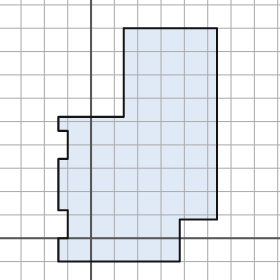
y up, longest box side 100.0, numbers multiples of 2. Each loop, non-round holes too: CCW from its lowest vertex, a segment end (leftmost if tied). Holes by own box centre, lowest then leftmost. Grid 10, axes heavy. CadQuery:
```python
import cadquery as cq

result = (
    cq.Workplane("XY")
    .moveTo(-14.0, -10.0)
    .lineTo(38.0, -10.0)
    .lineTo(38.0, 8.0)
    .lineTo(54.0, 8.0)
    .lineTo(54.0, 90.0)
    .lineTo(14.0, 90.0)
    .lineTo(14.0, 52.0)
    .lineTo(-14.0, 52.0)
    .lineTo(-14.0, 46.0)
    .lineTo(-10.0, 46.0)
    .lineTo(-10.0, 34.0)
    .lineTo(-14.0, 34.0)
    .lineTo(-14.0, 12.0)
    .lineTo(-10.0, 12.0)
    .lineTo(-10.0, 0.0)
    .lineTo(-14.0, 0.0)
    .close()
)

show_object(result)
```